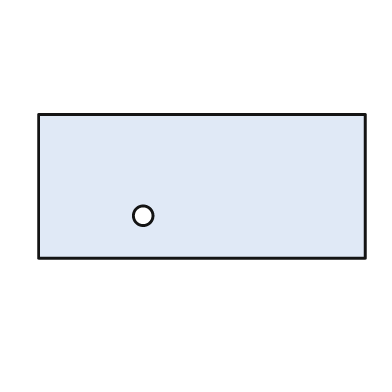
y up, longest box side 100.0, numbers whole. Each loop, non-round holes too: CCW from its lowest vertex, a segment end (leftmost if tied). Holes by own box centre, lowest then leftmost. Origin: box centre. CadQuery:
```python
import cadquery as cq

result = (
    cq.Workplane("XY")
    .moveTo(-50.0, -22.0)
    .lineTo(50.0, -22.0)
    .lineTo(50.0, 22.0)
    .lineTo(-50.0, 22.0)
    .close()
    .moveTo(-18.0, -9.0)
    .circle(3.0)
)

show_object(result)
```